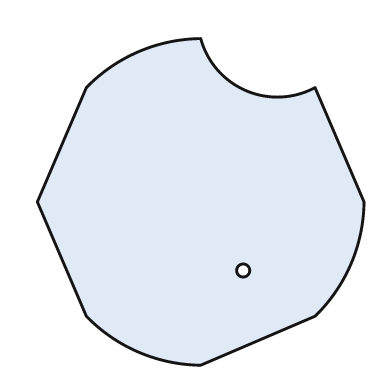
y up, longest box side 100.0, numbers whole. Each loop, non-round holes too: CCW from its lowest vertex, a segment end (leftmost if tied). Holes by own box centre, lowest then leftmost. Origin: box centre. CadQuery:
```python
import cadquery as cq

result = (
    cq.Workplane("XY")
    .moveTo(0.0, -50.0)
    .lineTo(35.0, -35.0)
    .threePointArc((46.0, -19.0), (50.0, 0.0))
    .lineTo(35.0, 35.0)
    .threePointArc((14.0, 34.0), (0.0, 50.0))
    .threePointArc((-19.0, 46.0), (-35.0, 35.0))
    .lineTo(-50.0, 0.0)
    .lineTo(-35.0, -35.0)
    .threePointArc((-19.0, -46.0), (0.0, -50.0))
    .close()
    .moveTo(13.0, -21.0)
    .circle(2.0)
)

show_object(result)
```